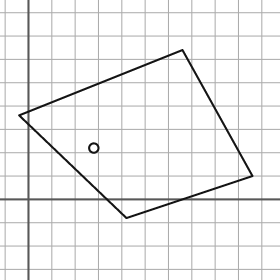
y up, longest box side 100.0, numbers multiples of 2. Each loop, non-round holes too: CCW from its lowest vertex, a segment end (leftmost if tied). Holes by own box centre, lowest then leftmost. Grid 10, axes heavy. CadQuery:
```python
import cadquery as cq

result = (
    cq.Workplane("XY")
    .moveTo(42.0, -8.0)
    .lineTo(96.0, 10.0)
    .lineTo(66.0, 64.0)
    .lineTo(-4.0, 36.0)
    .close()
    .moveTo(28.0, 22.0)
    .circle(2.0)
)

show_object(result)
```